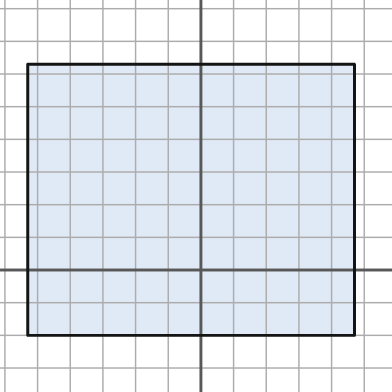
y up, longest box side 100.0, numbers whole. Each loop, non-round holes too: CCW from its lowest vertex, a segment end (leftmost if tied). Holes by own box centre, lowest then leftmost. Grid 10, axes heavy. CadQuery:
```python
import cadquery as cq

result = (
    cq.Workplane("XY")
    .moveTo(-53.0, -20.0)
    .lineTo(47.0, -20.0)
    .lineTo(47.0, 63.0)
    .lineTo(-53.0, 63.0)
    .close()
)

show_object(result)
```